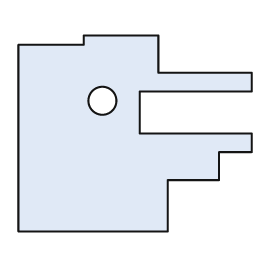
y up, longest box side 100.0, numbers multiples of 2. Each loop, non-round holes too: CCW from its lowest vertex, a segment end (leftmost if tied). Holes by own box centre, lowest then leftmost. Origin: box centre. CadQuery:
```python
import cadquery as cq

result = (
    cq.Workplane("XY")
    .moveTo(-50.0, -42.0)
    .lineTo(14.0, -42.0)
    .lineTo(14.0, -20.0)
    .lineTo(36.0, -20.0)
    .lineTo(36.0, -8.0)
    .lineTo(50.0, -8.0)
    .lineTo(50.0, 0.0)
    .lineTo(2.0, 0.0)
    .lineTo(2.0, 18.0)
    .lineTo(50.0, 18.0)
    .lineTo(50.0, 26.0)
    .lineTo(10.0, 26.0)
    .lineTo(10.0, 42.0)
    .lineTo(-22.0, 42.0)
    .lineTo(-22.0, 38.0)
    .lineTo(-50.0, 38.0)
    .close()
    .moveTo(-14.0, 14.0)
    .circle(6.0)
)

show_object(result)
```